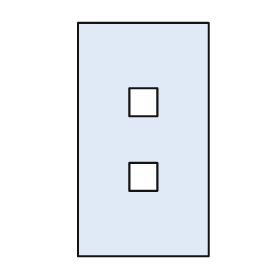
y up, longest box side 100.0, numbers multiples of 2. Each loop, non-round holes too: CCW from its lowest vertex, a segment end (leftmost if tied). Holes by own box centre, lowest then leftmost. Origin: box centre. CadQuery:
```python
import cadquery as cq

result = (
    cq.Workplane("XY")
    .moveTo(-28.0, -50.0)
    .lineTo(28.0, -50.0)
    .lineTo(28.0, 50.0)
    .lineTo(-28.0, 50.0)
    .close()
    .moveTo(-6.0, -22.0)
    .lineTo(6.0, -22.0)
    .lineTo(6.0, -10.0)
    .lineTo(-6.0, -10.0)
    .close()
    .moveTo(-6.0, 10.0)
    .lineTo(6.0, 10.0)
    .lineTo(6.0, 22.0)
    .lineTo(-6.0, 22.0)
    .close()
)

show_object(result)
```